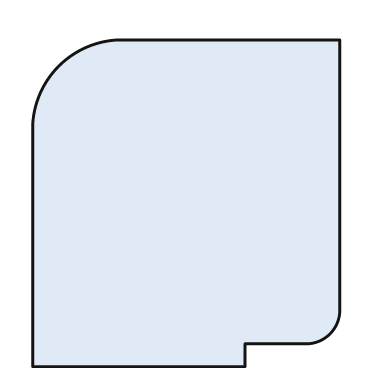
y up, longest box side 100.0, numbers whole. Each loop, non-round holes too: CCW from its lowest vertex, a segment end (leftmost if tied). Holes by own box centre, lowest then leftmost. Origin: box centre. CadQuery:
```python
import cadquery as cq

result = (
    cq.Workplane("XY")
    .moveTo(-47.0, -50.0)
    .lineTo(18.0, -50.0)
    .lineTo(18.0, -43.0)
    .lineTo(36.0, -43.0)
    .threePointArc((44.0, -40.0), (47.0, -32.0))
    .lineTo(47.0, 50.0)
    .lineTo(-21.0, 50.0)
    .threePointArc((-39.0, 42.0), (-47.0, 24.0))
    .close()
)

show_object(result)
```